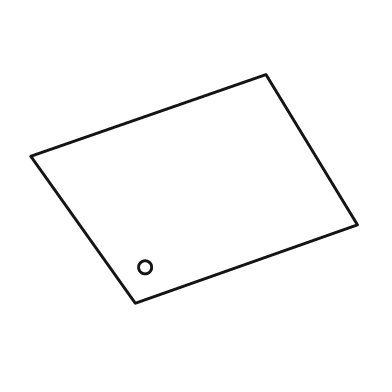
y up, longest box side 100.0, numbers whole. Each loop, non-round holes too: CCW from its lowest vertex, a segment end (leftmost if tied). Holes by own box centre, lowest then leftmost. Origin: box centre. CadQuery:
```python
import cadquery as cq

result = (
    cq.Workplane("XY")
    .moveTo(-18.0, -35.0)
    .lineTo(50.0, -11.0)
    .lineTo(22.0, 35.0)
    .lineTo(-50.0, 10.0)
    .close()
    .moveTo(-15.0, -24.0)
    .circle(2.0)
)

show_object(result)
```